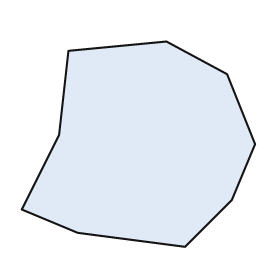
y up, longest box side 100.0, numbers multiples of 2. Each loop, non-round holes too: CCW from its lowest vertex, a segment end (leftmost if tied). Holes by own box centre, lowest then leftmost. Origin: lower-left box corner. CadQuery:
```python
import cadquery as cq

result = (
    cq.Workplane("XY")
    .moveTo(70.0, 0.0)
    .lineTo(90.0, 20.0)
    .lineTo(100.0, 44.0)
    .lineTo(88.0, 74.0)
    .lineTo(62.0, 88.0)
    .lineTo(20.0, 84.0)
    .lineTo(16.0, 48.0)
    .lineTo(0.0, 16.0)
    .lineTo(24.0, 6.0)
    .close()
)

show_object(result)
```